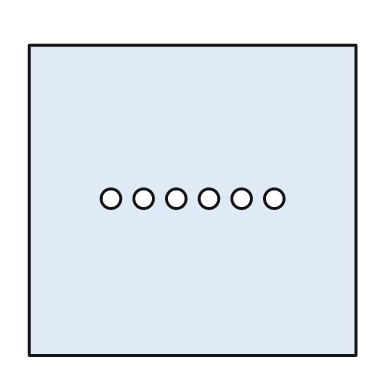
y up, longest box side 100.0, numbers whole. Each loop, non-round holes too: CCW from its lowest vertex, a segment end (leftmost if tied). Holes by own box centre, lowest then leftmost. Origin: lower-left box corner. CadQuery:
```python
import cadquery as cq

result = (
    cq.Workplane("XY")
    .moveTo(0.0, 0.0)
    .lineTo(100.0, 0.0)
    .lineTo(100.0, 95.0)
    .lineTo(0.0, 95.0)
    .close()
    .moveTo(25.0, 48.0)
    .circle(3.0)
    .moveTo(35.0, 48.0)
    .circle(3.0)
    .moveTo(45.0, 48.0)
    .circle(3.0)
    .moveTo(55.0, 48.0)
    .circle(3.0)
    .moveTo(65.0, 48.0)
    .circle(3.0)
    .moveTo(75.0, 48.0)
    .circle(3.0)
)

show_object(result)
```